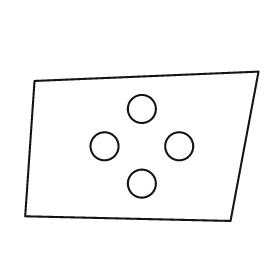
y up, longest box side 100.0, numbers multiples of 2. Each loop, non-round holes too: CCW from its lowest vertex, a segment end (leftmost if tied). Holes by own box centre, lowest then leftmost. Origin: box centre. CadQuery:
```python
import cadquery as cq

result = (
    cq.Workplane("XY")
    .moveTo(38.0, -32.0)
    .lineTo(50.0, 32.0)
    .lineTo(-46.0, 28.0)
    .lineTo(-50.0, -30.0)
    .close()
    .moveTo(0.0, -16.0)
    .circle(6.0)
    .moveTo(-16.0, 0.0)
    .circle(6.0)
    .moveTo(16.0, 0.0)
    .circle(6.0)
    .moveTo(0.0, 16.0)
    .circle(6.0)
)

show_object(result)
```